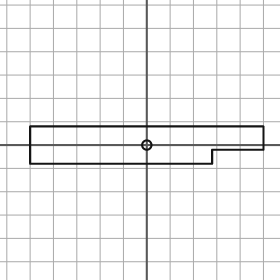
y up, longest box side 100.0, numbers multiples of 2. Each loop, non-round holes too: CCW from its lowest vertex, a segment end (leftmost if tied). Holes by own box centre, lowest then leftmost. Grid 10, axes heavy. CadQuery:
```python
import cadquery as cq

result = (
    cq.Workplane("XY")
    .moveTo(-50.0, -8.0)
    .lineTo(28.0, -8.0)
    .lineTo(28.0, -2.0)
    .lineTo(50.0, -2.0)
    .lineTo(50.0, 8.0)
    .lineTo(-50.0, 8.0)
    .close()
    .moveTo(0.0, 0.0)
    .circle(2.0)
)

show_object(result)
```